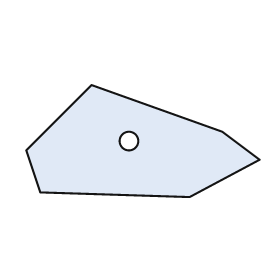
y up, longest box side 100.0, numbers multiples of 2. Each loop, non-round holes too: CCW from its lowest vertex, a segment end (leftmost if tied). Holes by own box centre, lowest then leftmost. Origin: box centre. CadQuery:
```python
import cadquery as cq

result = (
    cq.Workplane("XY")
    .moveTo(20.0, -24.0)
    .lineTo(50.0, -8.0)
    .lineTo(34.0, 4.0)
    .lineTo(-22.0, 24.0)
    .lineTo(-50.0, -4.0)
    .lineTo(-44.0, -22.0)
    .close()
    .moveTo(-6.0, 0.0)
    .circle(4.0)
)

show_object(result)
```